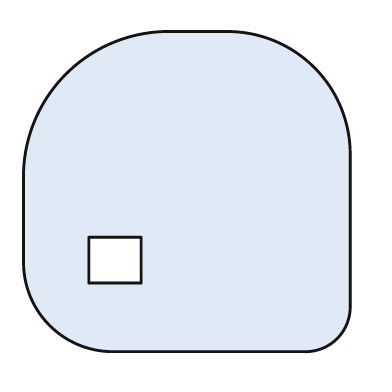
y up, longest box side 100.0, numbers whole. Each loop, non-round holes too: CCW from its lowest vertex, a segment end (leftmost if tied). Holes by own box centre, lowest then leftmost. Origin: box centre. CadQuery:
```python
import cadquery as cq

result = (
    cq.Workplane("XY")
    .moveTo(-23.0, -49.0)
    .lineTo(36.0, -49.0)
    .threePointArc((46.0, -45.0), (50.0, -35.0))
    .lineTo(50.0, 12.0)
    .threePointArc((39.0, 38.0), (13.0, 49.0))
    .lineTo(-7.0, 49.0)
    .threePointArc((-37.0, 36.0), (-50.0, 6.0))
    .lineTo(-50.0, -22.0)
    .threePointArc((-42.0, -41.0), (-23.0, -49.0))
    .close()
    .moveTo(-30.0, -28.0)
    .lineTo(-14.0, -28.0)
    .lineTo(-14.0, -14.0)
    .lineTo(-30.0, -14.0)
    .close()
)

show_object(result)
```